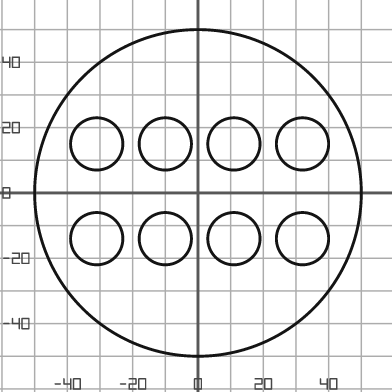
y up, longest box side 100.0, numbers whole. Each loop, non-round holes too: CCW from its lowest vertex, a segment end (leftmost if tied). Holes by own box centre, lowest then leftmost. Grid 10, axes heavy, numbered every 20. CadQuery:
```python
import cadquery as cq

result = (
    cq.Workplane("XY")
    .moveTo(0.0, 0.0)
    .circle(50.0)
    .moveTo(-31.0, -14.0)
    .circle(8.0)
    .moveTo(-10.0, -14.0)
    .circle(8.0)
    .moveTo(11.0, -14.0)
    .circle(8.0)
    .moveTo(32.0, -14.0)
    .circle(8.0)
    .moveTo(-31.0, 15.0)
    .circle(8.0)
    .moveTo(-10.0, 15.0)
    .circle(8.0)
    .moveTo(11.0, 15.0)
    .circle(8.0)
    .moveTo(32.0, 15.0)
    .circle(8.0)
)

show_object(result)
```